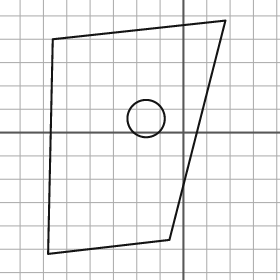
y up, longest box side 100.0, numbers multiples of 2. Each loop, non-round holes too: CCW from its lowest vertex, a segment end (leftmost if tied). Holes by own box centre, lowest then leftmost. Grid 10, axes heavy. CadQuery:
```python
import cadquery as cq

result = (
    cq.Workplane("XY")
    .moveTo(-58.0, -52.0)
    .lineTo(-6.0, -46.0)
    .lineTo(18.0, 48.0)
    .lineTo(-56.0, 40.0)
    .close()
    .moveTo(-16.0, 6.0)
    .circle(8.0)
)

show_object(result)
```